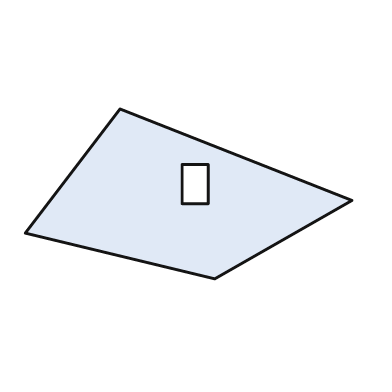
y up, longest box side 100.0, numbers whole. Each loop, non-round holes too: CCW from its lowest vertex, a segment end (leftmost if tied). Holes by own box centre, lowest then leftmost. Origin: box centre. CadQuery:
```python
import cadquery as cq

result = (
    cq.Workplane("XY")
    .moveTo(8.0, -26.0)
    .lineTo(50.0, -2.0)
    .lineTo(-21.0, 26.0)
    .lineTo(-50.0, -12.0)
    .close()
    .moveTo(-2.0, -3.0)
    .lineTo(6.0, -3.0)
    .lineTo(6.0, 9.0)
    .lineTo(-2.0, 9.0)
    .close()
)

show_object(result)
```